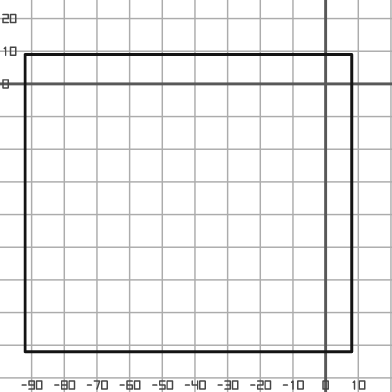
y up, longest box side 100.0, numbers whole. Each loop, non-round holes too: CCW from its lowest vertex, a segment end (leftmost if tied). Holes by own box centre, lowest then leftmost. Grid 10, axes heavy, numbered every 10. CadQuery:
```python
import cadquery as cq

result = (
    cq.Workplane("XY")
    .moveTo(-92.0, -82.0)
    .lineTo(8.0, -82.0)
    .lineTo(8.0, 9.0)
    .lineTo(-92.0, 9.0)
    .close()
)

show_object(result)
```